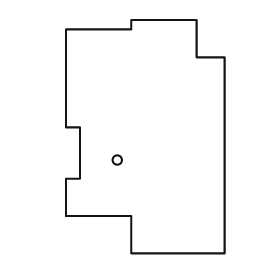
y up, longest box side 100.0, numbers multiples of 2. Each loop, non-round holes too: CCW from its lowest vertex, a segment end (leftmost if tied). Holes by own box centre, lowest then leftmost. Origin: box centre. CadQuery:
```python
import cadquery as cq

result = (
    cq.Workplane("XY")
    .moveTo(-6.0, -50.0)
    .lineTo(34.0, -50.0)
    .lineTo(34.0, 34.0)
    .lineTo(22.0, 34.0)
    .lineTo(22.0, 50.0)
    .lineTo(-6.0, 50.0)
    .lineTo(-6.0, 46.0)
    .lineTo(-34.0, 46.0)
    .lineTo(-34.0, 4.0)
    .lineTo(-28.0, 4.0)
    .lineTo(-28.0, -18.0)
    .lineTo(-34.0, -18.0)
    .lineTo(-34.0, -34.0)
    .lineTo(-6.0, -34.0)
    .close()
    .moveTo(-12.0, -10.0)
    .circle(2.0)
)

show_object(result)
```